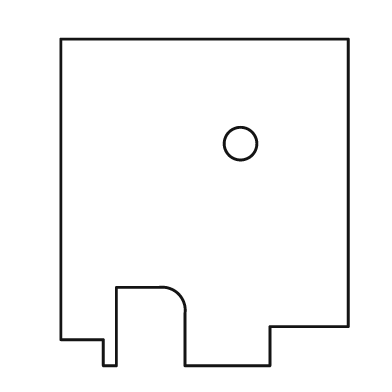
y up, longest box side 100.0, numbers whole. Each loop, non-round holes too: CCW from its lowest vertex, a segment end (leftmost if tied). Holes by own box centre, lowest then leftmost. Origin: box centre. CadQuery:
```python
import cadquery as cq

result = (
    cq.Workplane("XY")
    .moveTo(-31.0, -50.0)
    .lineTo(-27.0, -50.0)
    .lineTo(-27.0, -26.0)
    .lineTo(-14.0, -26.0)
    .threePointArc((-8.0, -28.0), (-6.0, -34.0))
    .lineTo(-6.0, -50.0)
    .lineTo(20.0, -50.0)
    .lineTo(20.0, -38.0)
    .lineTo(44.0, -38.0)
    .lineTo(44.0, 50.0)
    .lineTo(-44.0, 50.0)
    .lineTo(-44.0, -42.0)
    .lineTo(-31.0, -42.0)
    .close()
    .moveTo(11.0, 18.0)
    .circle(5.0)
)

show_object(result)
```